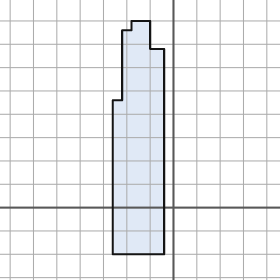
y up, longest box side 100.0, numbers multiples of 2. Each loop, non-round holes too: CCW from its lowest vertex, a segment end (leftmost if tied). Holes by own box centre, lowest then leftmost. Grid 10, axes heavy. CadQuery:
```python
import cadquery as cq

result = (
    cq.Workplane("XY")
    .moveTo(-26.0, -20.0)
    .lineTo(-4.0, -20.0)
    .lineTo(-4.0, 68.0)
    .lineTo(-10.0, 68.0)
    .lineTo(-10.0, 80.0)
    .lineTo(-18.0, 80.0)
    .lineTo(-18.0, 76.0)
    .lineTo(-22.0, 76.0)
    .lineTo(-22.0, 46.0)
    .lineTo(-26.0, 46.0)
    .close()
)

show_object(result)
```